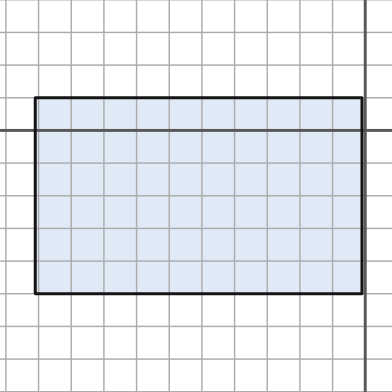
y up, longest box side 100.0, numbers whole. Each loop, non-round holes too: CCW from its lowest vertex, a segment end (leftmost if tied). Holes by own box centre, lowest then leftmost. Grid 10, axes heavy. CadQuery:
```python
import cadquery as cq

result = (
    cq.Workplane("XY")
    .moveTo(-101.0, -50.0)
    .lineTo(-1.0, -50.0)
    .lineTo(-1.0, 10.0)
    .lineTo(-101.0, 10.0)
    .close()
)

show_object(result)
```